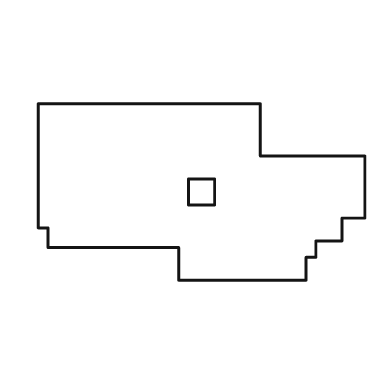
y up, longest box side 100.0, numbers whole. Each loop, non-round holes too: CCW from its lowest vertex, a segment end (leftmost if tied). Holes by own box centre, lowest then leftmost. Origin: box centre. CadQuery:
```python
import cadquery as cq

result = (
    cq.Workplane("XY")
    .moveTo(-7.0, -27.0)
    .lineTo(32.0, -27.0)
    .lineTo(32.0, -20.0)
    .lineTo(35.0, -20.0)
    .lineTo(35.0, -15.0)
    .lineTo(43.0, -15.0)
    .lineTo(43.0, -8.0)
    .lineTo(50.0, -8.0)
    .lineTo(50.0, 11.0)
    .lineTo(18.0, 11.0)
    .lineTo(18.0, 27.0)
    .lineTo(-50.0, 27.0)
    .lineTo(-50.0, -11.0)
    .lineTo(-47.0, -11.0)
    .lineTo(-47.0, -17.0)
    .lineTo(-7.0, -17.0)
    .close()
    .moveTo(-4.0, -4.0)
    .lineTo(4.0, -4.0)
    .lineTo(4.0, 4.0)
    .lineTo(-4.0, 4.0)
    .close()
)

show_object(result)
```